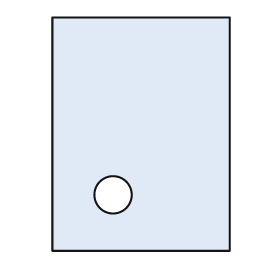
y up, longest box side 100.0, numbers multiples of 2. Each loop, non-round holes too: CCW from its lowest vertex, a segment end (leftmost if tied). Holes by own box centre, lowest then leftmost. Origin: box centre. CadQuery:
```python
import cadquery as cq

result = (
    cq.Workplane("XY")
    .moveTo(-38.0, -50.0)
    .lineTo(38.0, -50.0)
    .lineTo(38.0, 50.0)
    .lineTo(-38.0, 50.0)
    .close()
    .moveTo(-12.0, -26.0)
    .circle(8.0)
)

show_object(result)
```